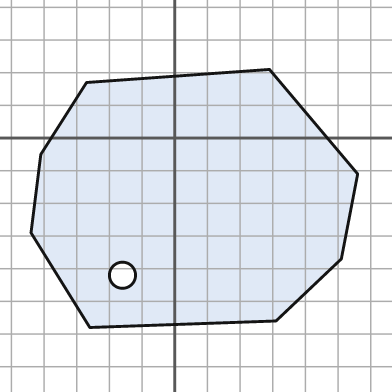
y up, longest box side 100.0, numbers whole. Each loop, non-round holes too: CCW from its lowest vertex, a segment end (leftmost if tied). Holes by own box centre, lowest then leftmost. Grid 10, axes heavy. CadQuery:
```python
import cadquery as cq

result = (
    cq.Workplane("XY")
    .moveTo(-26.0, -58.0)
    .lineTo(31.0, -56.0)
    .lineTo(51.0, -37.0)
    .lineTo(56.0, -11.0)
    .lineTo(29.0, 21.0)
    .lineTo(-27.0, 17.0)
    .lineTo(-41.0, -5.0)
    .lineTo(-44.0, -29.0)
    .close()
    .moveTo(-16.0, -42.0)
    .circle(4.0)
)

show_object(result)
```